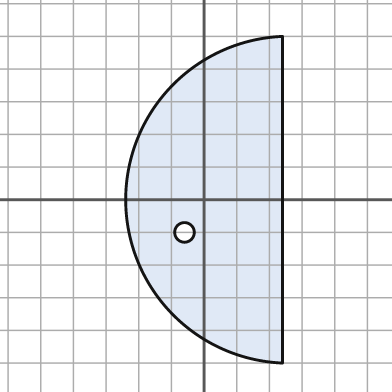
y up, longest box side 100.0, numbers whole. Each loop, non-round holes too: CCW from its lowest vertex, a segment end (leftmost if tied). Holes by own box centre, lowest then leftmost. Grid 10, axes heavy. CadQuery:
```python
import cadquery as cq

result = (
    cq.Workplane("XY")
    .moveTo(24.0, -50.0)
    .lineTo(24.0, 50.0)
    .threePointArc((-24.0, 0.0), (24.0, -50.0))
    .close()
    .moveTo(-6.0, -10.0)
    .circle(3.0)
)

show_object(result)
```